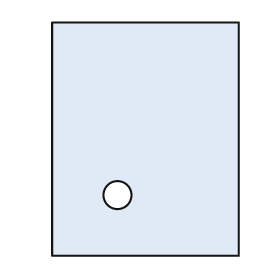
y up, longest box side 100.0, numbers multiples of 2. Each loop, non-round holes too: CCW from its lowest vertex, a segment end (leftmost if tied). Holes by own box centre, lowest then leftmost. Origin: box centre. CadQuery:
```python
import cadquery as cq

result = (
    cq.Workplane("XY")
    .moveTo(-40.0, -50.0)
    .lineTo(40.0, -50.0)
    .lineTo(40.0, 50.0)
    .lineTo(-40.0, 50.0)
    .close()
    .moveTo(-12.0, -24.0)
    .circle(6.0)
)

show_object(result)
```